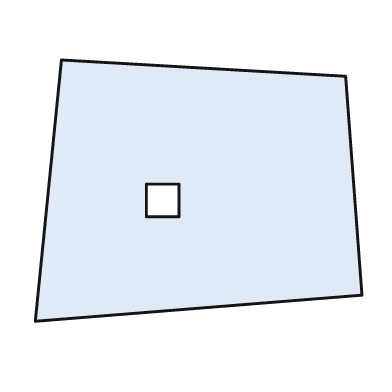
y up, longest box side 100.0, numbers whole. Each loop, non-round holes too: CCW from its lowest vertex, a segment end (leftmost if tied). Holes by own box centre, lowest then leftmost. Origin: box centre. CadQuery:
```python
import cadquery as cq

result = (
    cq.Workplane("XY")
    .moveTo(-50.0, -40.0)
    .lineTo(50.0, -32.0)
    .lineTo(45.0, 35.0)
    .lineTo(-42.0, 40.0)
    .close()
    .moveTo(-16.0, -8.0)
    .lineTo(-6.0, -8.0)
    .lineTo(-6.0, 2.0)
    .lineTo(-16.0, 2.0)
    .close()
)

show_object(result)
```